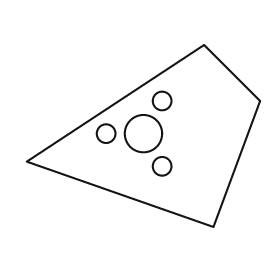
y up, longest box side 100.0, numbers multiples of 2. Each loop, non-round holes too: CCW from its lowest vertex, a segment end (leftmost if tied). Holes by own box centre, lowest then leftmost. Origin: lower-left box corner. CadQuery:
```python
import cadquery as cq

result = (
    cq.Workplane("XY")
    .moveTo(80.0, 0.0)
    .lineTo(100.0, 54.0)
    .lineTo(76.0, 78.0)
    .lineTo(0.0, 28.0)
    .close()
    .moveTo(58.0, 26.0)
    .circle(4.0)
    .moveTo(34.0, 40.0)
    .circle(4.0)
    .moveTo(50.0, 40.0)
    .circle(8.0)
    .moveTo(58.0, 54.0)
    .circle(4.0)
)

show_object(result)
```